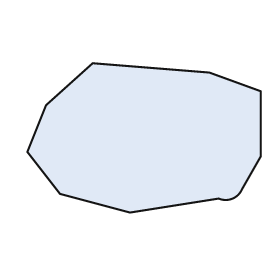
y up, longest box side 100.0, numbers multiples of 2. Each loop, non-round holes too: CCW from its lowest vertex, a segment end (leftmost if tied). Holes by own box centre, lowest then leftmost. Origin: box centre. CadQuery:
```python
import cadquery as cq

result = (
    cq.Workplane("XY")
    .moveTo(-6.0, -32.0)
    .lineTo(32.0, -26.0)
    .threePointArc((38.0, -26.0), (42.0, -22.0))
    .lineTo(50.0, -8.0)
    .lineTo(50.0, 20.0)
    .lineTo(28.0, 28.0)
    .lineTo(-22.0, 32.0)
    .lineTo(-42.0, 14.0)
    .lineTo(-50.0, -6.0)
    .lineTo(-36.0, -24.0)
    .close()
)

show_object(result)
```